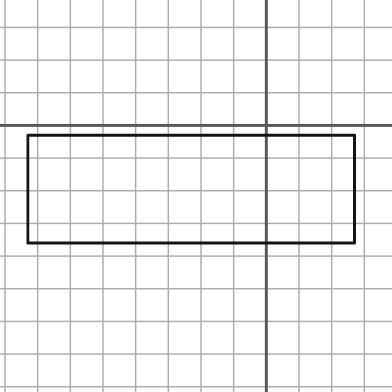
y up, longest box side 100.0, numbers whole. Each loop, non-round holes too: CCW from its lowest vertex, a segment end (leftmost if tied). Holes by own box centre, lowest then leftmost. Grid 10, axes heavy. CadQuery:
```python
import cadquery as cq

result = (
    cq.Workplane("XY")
    .moveTo(-73.0, -36.0)
    .lineTo(27.0, -36.0)
    .lineTo(27.0, -3.0)
    .lineTo(-73.0, -3.0)
    .close()
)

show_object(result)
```